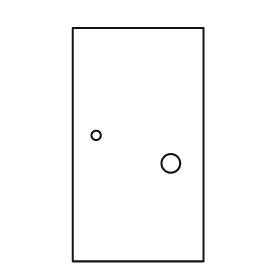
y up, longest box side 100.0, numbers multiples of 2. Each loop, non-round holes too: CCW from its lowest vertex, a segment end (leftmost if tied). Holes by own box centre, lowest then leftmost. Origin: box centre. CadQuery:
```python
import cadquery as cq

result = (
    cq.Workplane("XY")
    .moveTo(-28.0, -50.0)
    .lineTo(28.0, -50.0)
    .lineTo(28.0, 50.0)
    .lineTo(-28.0, 50.0)
    .close()
    .moveTo(14.0, -8.0)
    .circle(4.0)
    .moveTo(-18.0, 4.0)
    .circle(2.0)
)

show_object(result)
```